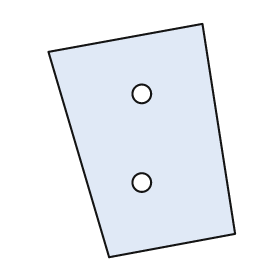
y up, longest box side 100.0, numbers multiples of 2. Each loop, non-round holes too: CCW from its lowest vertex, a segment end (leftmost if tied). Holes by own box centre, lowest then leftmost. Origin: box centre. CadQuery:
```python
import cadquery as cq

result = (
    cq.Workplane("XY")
    .moveTo(-14.0, -50.0)
    .lineTo(40.0, -40.0)
    .lineTo(26.0, 50.0)
    .lineTo(-40.0, 38.0)
    .close()
    .moveTo(0.0, -18.0)
    .circle(4.0)
    .moveTo(0.0, 20.0)
    .circle(4.0)
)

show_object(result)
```